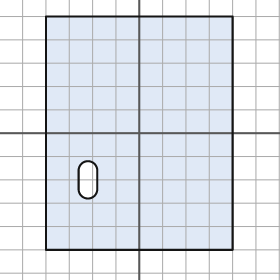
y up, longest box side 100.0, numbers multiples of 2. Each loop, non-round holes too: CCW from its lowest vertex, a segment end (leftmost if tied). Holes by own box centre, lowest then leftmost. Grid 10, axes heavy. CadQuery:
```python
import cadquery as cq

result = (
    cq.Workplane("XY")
    .moveTo(-40.0, -50.0)
    .lineTo(40.0, -50.0)
    .lineTo(40.0, 50.0)
    .lineTo(-40.0, 50.0)
    .close()
    .moveTo(-26.0, -24.0)
    .threePointArc((-22.0, -28.0), (-18.0, -24.0))
    .lineTo(-18.0, -16.0)
    .threePointArc((-22.0, -12.0), (-26.0, -16.0))
    .close()
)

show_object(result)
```